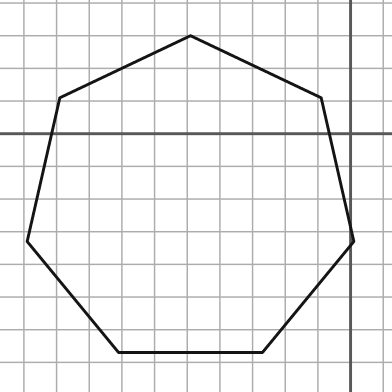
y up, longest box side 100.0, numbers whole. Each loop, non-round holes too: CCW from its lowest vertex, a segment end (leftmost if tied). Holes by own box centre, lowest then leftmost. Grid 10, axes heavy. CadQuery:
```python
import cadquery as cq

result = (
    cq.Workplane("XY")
    .moveTo(-71.0, -67.0)
    .lineTo(-27.0, -67.0)
    .lineTo(1.0, -33.0)
    .lineTo(-9.0, 11.0)
    .lineTo(-49.0, 30.0)
    .lineTo(-89.0, 11.0)
    .lineTo(-99.0, -33.0)
    .close()
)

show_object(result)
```